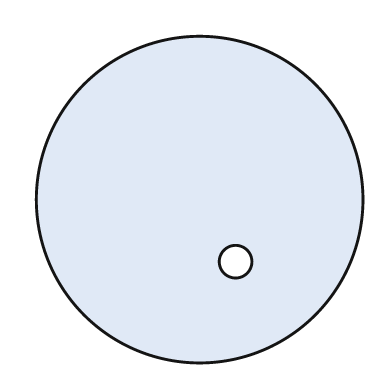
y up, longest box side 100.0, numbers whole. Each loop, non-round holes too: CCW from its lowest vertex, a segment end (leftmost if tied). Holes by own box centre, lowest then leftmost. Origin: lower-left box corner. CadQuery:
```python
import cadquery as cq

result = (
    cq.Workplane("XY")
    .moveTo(50.0, 50.0)
    .circle(50.0)
    .moveTo(61.0, 31.0)
    .circle(5.0)
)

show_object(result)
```